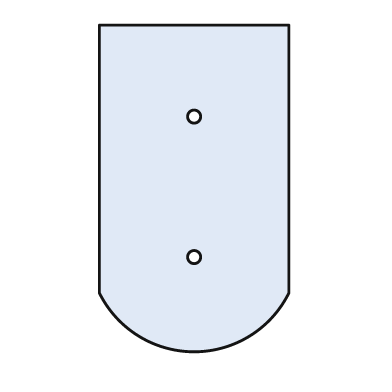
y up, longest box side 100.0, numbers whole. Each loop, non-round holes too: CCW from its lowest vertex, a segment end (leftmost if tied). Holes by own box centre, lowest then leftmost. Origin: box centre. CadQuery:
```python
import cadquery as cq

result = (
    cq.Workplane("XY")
    .moveTo(-29.0, -32.0)
    .threePointArc((0.0, -50.0), (29.0, -32.0))
    .lineTo(29.0, 50.0)
    .lineTo(-29.0, 50.0)
    .close()
    .moveTo(0.0, -21.0)
    .circle(2.0)
    .moveTo(0.0, 22.0)
    .circle(2.0)
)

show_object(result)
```